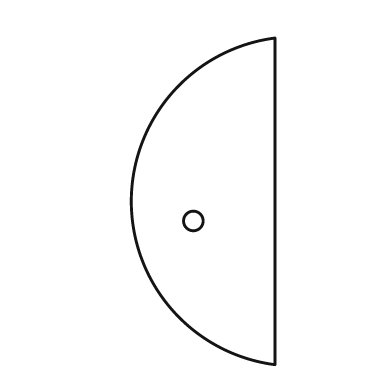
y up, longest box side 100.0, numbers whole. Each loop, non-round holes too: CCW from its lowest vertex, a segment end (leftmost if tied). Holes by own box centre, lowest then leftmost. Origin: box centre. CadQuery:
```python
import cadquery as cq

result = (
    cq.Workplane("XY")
    .moveTo(22.0, -50.0)
    .lineTo(22.0, 50.0)
    .threePointArc((-22.0, 0.0), (22.0, -50.0))
    .close()
    .moveTo(-3.0, -6.0)
    .circle(3.0)
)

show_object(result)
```